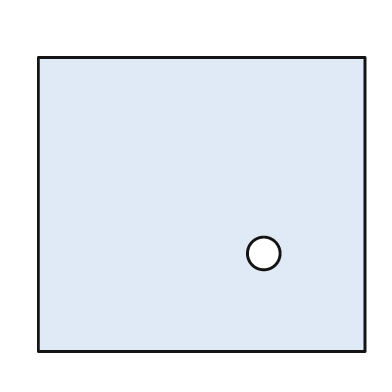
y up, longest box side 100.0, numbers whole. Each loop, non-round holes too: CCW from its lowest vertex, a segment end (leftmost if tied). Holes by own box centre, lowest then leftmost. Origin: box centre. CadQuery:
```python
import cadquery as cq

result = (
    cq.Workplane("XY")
    .moveTo(-50.0, -45.0)
    .lineTo(50.0, -45.0)
    .lineTo(50.0, 45.0)
    .lineTo(-50.0, 45.0)
    .close()
    .moveTo(19.0, -15.0)
    .circle(5.0)
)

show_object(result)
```